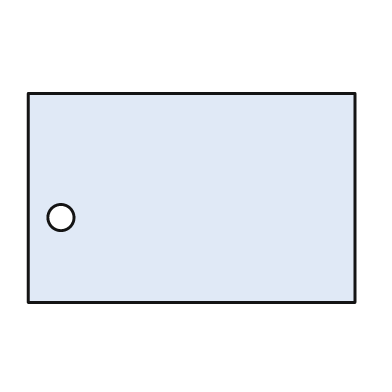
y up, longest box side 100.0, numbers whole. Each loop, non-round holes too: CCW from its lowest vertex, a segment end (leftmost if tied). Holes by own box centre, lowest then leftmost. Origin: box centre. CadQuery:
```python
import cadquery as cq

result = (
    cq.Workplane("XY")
    .moveTo(-50.0, -32.0)
    .lineTo(50.0, -32.0)
    .lineTo(50.0, 32.0)
    .lineTo(-50.0, 32.0)
    .close()
    .moveTo(-40.0, -6.0)
    .circle(4.0)
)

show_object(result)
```